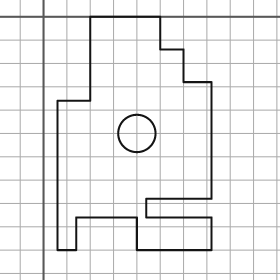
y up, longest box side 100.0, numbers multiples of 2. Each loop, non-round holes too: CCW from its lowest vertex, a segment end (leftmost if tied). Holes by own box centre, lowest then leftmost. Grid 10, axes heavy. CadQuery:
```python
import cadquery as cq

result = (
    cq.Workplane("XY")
    .moveTo(6.0, -100.0)
    .lineTo(14.0, -100.0)
    .lineTo(14.0, -86.0)
    .lineTo(40.0, -86.0)
    .lineTo(40.0, -100.0)
    .lineTo(72.0, -100.0)
    .lineTo(72.0, -86.0)
    .lineTo(44.0, -86.0)
    .lineTo(44.0, -78.0)
    .lineTo(72.0, -78.0)
    .lineTo(72.0, -28.0)
    .lineTo(60.0, -28.0)
    .lineTo(60.0, -14.0)
    .lineTo(50.0, -14.0)
    .lineTo(50.0, 0.0)
    .lineTo(20.0, 0.0)
    .lineTo(20.0, -36.0)
    .lineTo(6.0, -36.0)
    .close()
    .moveTo(40.0, -50.0)
    .circle(8.0)
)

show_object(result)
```